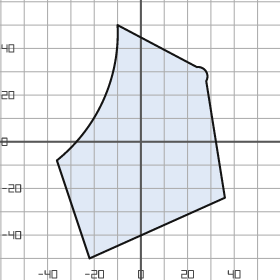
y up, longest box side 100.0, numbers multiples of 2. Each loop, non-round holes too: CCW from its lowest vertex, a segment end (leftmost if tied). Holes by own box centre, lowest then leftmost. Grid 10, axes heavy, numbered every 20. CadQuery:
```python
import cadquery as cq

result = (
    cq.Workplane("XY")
    .moveTo(-22.0, -50.0)
    .lineTo(36.0, -24.0)
    .lineTo(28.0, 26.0)
    .threePointArc((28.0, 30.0), (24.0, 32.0))
    .lineTo(-10.0, 50.0)
    .threePointArc((-16.0, 18.0), (-36.0, -8.0))
    .close()
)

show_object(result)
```